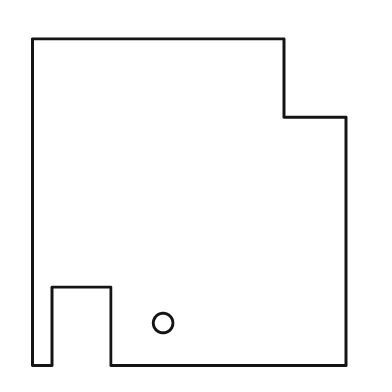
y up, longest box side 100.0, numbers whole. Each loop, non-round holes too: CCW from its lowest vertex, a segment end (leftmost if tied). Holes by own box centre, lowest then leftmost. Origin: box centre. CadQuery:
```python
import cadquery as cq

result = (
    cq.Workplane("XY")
    .moveTo(-48.0, -50.0)
    .lineTo(-42.0, -50.0)
    .lineTo(-42.0, -26.0)
    .lineTo(-24.0, -26.0)
    .lineTo(-24.0, -50.0)
    .lineTo(48.0, -50.0)
    .lineTo(48.0, 26.0)
    .lineTo(29.0, 26.0)
    .lineTo(29.0, 50.0)
    .lineTo(-48.0, 50.0)
    .close()
    .moveTo(-8.0, -37.0)
    .circle(3.0)
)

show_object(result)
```